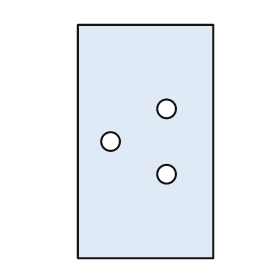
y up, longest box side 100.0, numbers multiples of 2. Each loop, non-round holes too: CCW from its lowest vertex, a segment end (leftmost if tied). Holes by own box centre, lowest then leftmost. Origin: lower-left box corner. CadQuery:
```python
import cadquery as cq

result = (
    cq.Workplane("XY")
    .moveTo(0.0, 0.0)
    .lineTo(58.0, 0.0)
    .lineTo(58.0, 100.0)
    .lineTo(0.0, 100.0)
    .close()
    .moveTo(38.0, 36.0)
    .circle(4.0)
    .moveTo(14.0, 50.0)
    .circle(4.0)
    .moveTo(38.0, 64.0)
    .circle(4.0)
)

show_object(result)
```